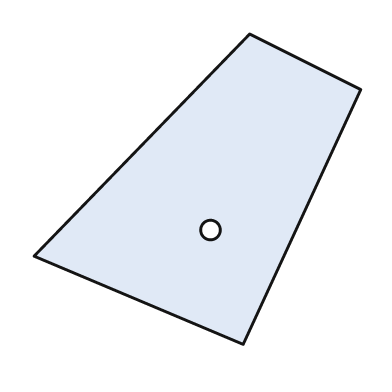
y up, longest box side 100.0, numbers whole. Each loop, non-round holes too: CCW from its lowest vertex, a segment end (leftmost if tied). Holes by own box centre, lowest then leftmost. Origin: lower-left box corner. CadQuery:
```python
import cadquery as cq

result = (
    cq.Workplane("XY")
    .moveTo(64.0, 0.0)
    .lineTo(100.0, 78.0)
    .lineTo(66.0, 95.0)
    .lineTo(0.0, 27.0)
    .close()
    .moveTo(54.0, 35.0)
    .circle(3.0)
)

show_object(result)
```